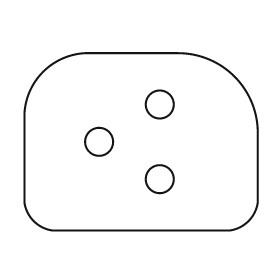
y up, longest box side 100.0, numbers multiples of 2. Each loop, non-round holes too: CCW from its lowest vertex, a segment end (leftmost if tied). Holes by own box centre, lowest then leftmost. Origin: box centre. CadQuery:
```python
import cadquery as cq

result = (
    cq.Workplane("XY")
    .moveTo(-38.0, -38.0)
    .lineTo(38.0, -38.0)
    .threePointArc((46.0, -34.0), (50.0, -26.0))
    .lineTo(50.0, 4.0)
    .threePointArc((40.0, 28.0), (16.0, 38.0))
    .lineTo(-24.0, 38.0)
    .threePointArc((-42.0, 30.0), (-50.0, 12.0))
    .lineTo(-50.0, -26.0)
    .threePointArc((-46.0, -34.0), (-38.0, -38.0))
    .close()
    .moveTo(8.0, -16.0)
    .circle(6.0)
    .moveTo(-18.0, 0.0)
    .circle(6.0)
    .moveTo(8.0, 16.0)
    .circle(6.0)
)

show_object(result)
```